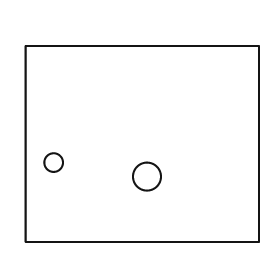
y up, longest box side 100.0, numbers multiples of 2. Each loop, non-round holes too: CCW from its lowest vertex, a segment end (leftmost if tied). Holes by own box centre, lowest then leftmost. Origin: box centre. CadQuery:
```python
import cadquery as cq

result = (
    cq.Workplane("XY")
    .moveTo(-50.0, -42.0)
    .lineTo(50.0, -42.0)
    .lineTo(50.0, 42.0)
    .lineTo(-50.0, 42.0)
    .close()
    .moveTo(2.0, -14.0)
    .circle(6.0)
    .moveTo(-38.0, -8.0)
    .circle(4.0)
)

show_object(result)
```